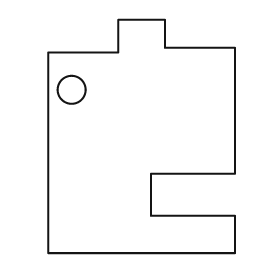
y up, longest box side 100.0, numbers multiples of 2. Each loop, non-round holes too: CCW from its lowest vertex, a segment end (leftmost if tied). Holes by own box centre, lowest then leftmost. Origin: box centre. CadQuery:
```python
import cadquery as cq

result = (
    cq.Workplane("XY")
    .moveTo(-40.0, -50.0)
    .lineTo(40.0, -50.0)
    .lineTo(40.0, -34.0)
    .lineTo(4.0, -34.0)
    .lineTo(4.0, -16.0)
    .lineTo(40.0, -16.0)
    .lineTo(40.0, 38.0)
    .lineTo(10.0, 38.0)
    .lineTo(10.0, 50.0)
    .lineTo(-10.0, 50.0)
    .lineTo(-10.0, 36.0)
    .lineTo(-40.0, 36.0)
    .close()
    .moveTo(-30.0, 20.0)
    .circle(6.0)
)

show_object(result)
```